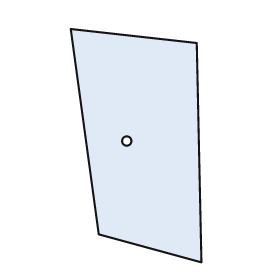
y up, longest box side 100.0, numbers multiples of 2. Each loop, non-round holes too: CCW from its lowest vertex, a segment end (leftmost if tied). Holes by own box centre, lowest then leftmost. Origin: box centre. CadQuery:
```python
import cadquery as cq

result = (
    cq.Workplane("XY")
    .moveTo(28.0, -50.0)
    .lineTo(26.0, 44.0)
    .lineTo(-28.0, 50.0)
    .lineTo(-16.0, -38.0)
    .close()
    .moveTo(-4.0, 2.0)
    .circle(2.0)
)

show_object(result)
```